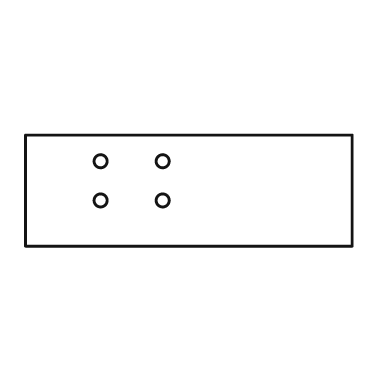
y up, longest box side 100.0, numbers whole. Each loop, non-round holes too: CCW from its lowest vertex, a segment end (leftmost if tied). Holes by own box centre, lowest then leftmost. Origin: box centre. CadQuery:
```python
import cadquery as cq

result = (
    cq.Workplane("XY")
    .moveTo(-50.0, -17.0)
    .lineTo(50.0, -17.0)
    .lineTo(50.0, 17.0)
    .lineTo(-50.0, 17.0)
    .close()
    .moveTo(-27.0, -3.0)
    .circle(2.0)
    .moveTo(-8.0, -3.0)
    .circle(2.0)
    .moveTo(-27.0, 9.0)
    .circle(2.0)
    .moveTo(-8.0, 9.0)
    .circle(2.0)
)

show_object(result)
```